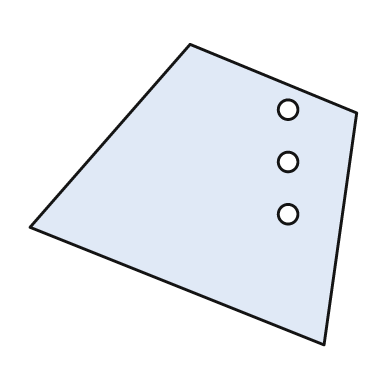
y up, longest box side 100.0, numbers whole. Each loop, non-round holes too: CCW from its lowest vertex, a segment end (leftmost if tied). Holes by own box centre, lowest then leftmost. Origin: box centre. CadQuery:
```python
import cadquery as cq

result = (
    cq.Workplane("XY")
    .moveTo(40.0, -46.0)
    .lineTo(50.0, 25.0)
    .lineTo(-1.0, 46.0)
    .lineTo(-50.0, -10.0)
    .close()
    .moveTo(29.0, -6.0)
    .circle(3.0)
    .moveTo(29.0, 10.0)
    .circle(3.0)
    .moveTo(29.0, 26.0)
    .circle(3.0)
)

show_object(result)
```